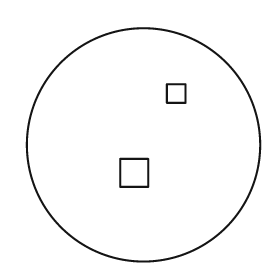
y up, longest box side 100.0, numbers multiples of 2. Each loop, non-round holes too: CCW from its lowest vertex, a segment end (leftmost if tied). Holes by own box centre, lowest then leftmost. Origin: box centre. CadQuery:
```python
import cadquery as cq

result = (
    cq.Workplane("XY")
    .moveTo(0.0, 0.0)
    .circle(50.0)
    .moveTo(-10.0, -18.0)
    .lineTo(2.0, -18.0)
    .lineTo(2.0, -6.0)
    .lineTo(-10.0, -6.0)
    .close()
    .moveTo(10.0, 18.0)
    .lineTo(18.0, 18.0)
    .lineTo(18.0, 26.0)
    .lineTo(10.0, 26.0)
    .close()
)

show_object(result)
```